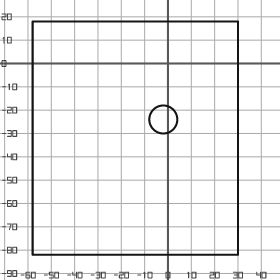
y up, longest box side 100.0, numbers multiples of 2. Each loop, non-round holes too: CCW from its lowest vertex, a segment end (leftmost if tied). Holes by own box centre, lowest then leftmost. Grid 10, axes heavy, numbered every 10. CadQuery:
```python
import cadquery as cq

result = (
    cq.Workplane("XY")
    .moveTo(-58.0, -82.0)
    .lineTo(30.0, -82.0)
    .lineTo(30.0, 18.0)
    .lineTo(-58.0, 18.0)
    .close()
    .moveTo(-2.0, -24.0)
    .circle(6.0)
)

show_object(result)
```